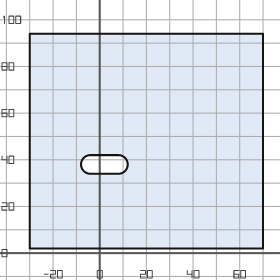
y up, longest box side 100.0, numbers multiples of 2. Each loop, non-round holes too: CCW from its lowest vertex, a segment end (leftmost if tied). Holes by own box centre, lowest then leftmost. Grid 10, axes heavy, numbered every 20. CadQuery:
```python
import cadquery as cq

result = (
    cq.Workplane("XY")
    .moveTo(-30.0, 2.0)
    .lineTo(70.0, 2.0)
    .lineTo(70.0, 94.0)
    .lineTo(-30.0, 94.0)
    .close()
    .moveTo(-4.0, 34.0)
    .lineTo(8.0, 34.0)
    .threePointArc((12.0, 38.0), (8.0, 42.0))
    .lineTo(-4.0, 42.0)
    .threePointArc((-8.0, 38.0), (-4.0, 34.0))
    .close()
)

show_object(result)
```